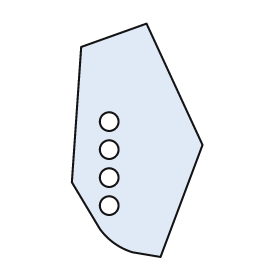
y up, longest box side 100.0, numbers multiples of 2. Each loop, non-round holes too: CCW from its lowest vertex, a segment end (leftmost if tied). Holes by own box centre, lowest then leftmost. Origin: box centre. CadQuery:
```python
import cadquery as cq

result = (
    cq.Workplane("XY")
    .moveTo(10.0, -50.0)
    .lineTo(28.0, -2.0)
    .lineTo(4.0, 50.0)
    .lineTo(-24.0, 40.0)
    .lineTo(-28.0, -18.0)
    .lineTo(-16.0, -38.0)
    .threePointArc((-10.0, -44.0), (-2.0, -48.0))
    .close()
    .moveTo(-12.0, -28.0)
    .circle(4.0)
    .moveTo(-12.0, -16.0)
    .circle(4.0)
    .moveTo(-12.0, -4.0)
    .circle(4.0)
    .moveTo(-12.0, 8.0)
    .circle(4.0)
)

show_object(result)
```